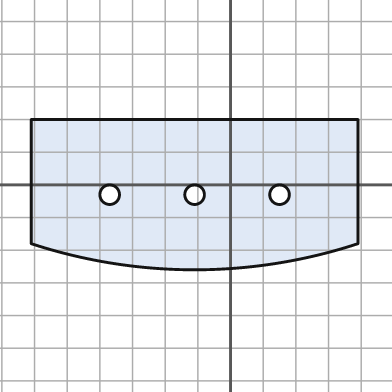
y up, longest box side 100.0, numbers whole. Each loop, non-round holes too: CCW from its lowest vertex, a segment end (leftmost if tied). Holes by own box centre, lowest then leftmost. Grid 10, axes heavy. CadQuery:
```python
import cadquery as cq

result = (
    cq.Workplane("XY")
    .moveTo(-61.0, -18.0)
    .threePointArc((-11.0, -26.0), (39.0, -18.0))
    .lineTo(39.0, 20.0)
    .lineTo(-61.0, 20.0)
    .close()
    .moveTo(-37.0, -3.0)
    .circle(3.0)
    .moveTo(-11.0, -3.0)
    .circle(3.0)
    .moveTo(15.0, -3.0)
    .circle(3.0)
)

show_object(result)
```